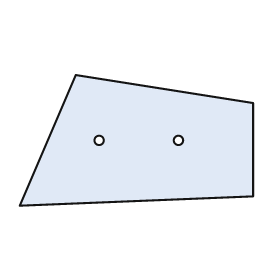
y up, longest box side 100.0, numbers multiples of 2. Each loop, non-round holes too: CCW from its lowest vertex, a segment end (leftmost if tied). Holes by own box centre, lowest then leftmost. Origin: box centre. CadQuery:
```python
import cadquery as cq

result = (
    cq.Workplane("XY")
    .moveTo(-50.0, -28.0)
    .lineTo(50.0, -24.0)
    .lineTo(50.0, 16.0)
    .lineTo(-26.0, 28.0)
    .close()
    .moveTo(-16.0, 0.0)
    .circle(2.0)
    .moveTo(18.0, 0.0)
    .circle(2.0)
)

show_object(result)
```